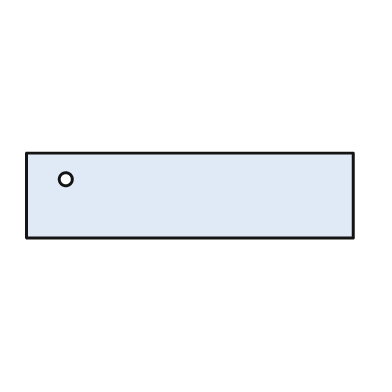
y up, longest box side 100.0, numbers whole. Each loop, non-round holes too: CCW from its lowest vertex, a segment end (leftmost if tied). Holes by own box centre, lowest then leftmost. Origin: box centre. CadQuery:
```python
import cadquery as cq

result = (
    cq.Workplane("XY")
    .moveTo(-50.0, -13.0)
    .lineTo(50.0, -13.0)
    .lineTo(50.0, 13.0)
    .lineTo(-50.0, 13.0)
    .close()
    .moveTo(-38.0, 5.0)
    .circle(2.0)
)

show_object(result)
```